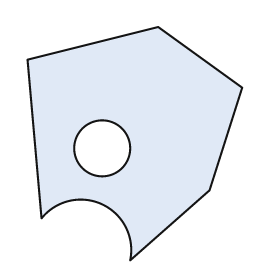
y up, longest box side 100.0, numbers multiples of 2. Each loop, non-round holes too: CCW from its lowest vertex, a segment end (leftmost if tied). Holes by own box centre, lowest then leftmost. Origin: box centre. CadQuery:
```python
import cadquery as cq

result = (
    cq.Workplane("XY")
    .moveTo(-2.0, -50.0)
    .lineTo(32.0, -20.0)
    .lineTo(46.0, 24.0)
    .lineTo(10.0, 50.0)
    .lineTo(-46.0, 36.0)
    .lineTo(-40.0, -32.0)
    .threePointArc((-14.0, -26.0), (-2.0, -50.0))
    .close()
    .moveTo(-14.0, -2.0)
    .circle(12.0)
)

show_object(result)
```